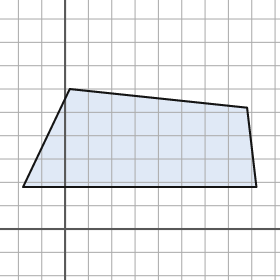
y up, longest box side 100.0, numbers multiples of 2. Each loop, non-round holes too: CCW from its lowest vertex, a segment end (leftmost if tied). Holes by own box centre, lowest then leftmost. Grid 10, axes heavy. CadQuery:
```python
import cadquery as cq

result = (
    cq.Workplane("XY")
    .moveTo(-18.0, 18.0)
    .lineTo(82.0, 18.0)
    .lineTo(78.0, 52.0)
    .lineTo(2.0, 60.0)
    .close()
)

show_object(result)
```